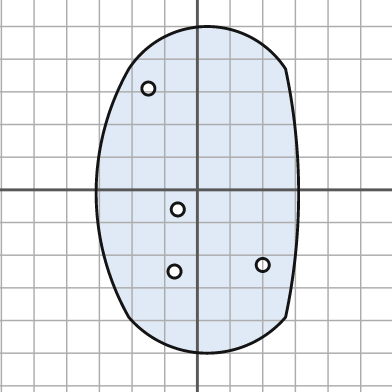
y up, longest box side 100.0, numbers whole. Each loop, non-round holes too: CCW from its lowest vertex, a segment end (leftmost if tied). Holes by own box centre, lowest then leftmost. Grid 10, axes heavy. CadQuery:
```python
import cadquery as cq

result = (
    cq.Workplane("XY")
    .moveTo(-21.0, -39.0)
    .threePointArc((3.0, -50.0), (27.0, -39.0))
    .threePointArc((31.0, -1.0), (27.0, 37.0))
    .threePointArc((3.0, 50.0), (-21.0, 37.0))
    .threePointArc((-31.0, -1.0), (-21.0, -39.0))
    .close()
    .moveTo(-7.0, -25.0)
    .circle(2.0)
    .moveTo(20.0, -23.0)
    .circle(2.0)
    .moveTo(-6.0, -6.0)
    .circle(2.0)
    .moveTo(-15.0, 31.0)
    .circle(2.0)
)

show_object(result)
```